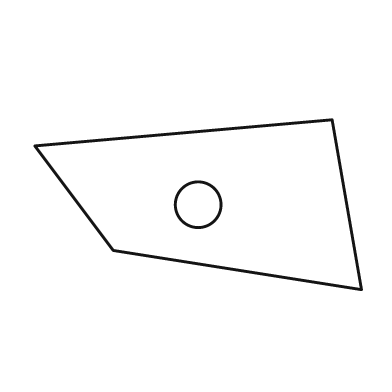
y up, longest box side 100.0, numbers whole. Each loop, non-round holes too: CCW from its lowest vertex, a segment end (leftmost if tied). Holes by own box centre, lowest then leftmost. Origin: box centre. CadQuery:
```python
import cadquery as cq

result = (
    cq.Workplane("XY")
    .moveTo(50.0, -26.0)
    .lineTo(41.0, 26.0)
    .lineTo(-50.0, 18.0)
    .lineTo(-26.0, -14.0)
    .close()
    .moveTo(0.0, 0.0)
    .circle(7.0)
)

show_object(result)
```